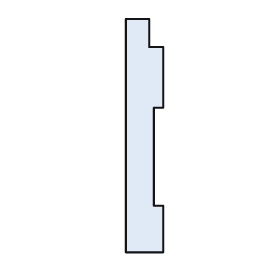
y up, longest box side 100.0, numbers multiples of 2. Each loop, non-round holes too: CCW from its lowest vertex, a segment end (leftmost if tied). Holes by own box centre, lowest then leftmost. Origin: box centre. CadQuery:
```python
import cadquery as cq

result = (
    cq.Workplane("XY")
    .moveTo(-8.0, -50.0)
    .lineTo(8.0, -50.0)
    .lineTo(8.0, -30.0)
    .lineTo(4.0, -30.0)
    .lineTo(4.0, 12.0)
    .lineTo(8.0, 12.0)
    .lineTo(8.0, 38.0)
    .lineTo(2.0, 38.0)
    .lineTo(2.0, 50.0)
    .lineTo(-8.0, 50.0)
    .close()
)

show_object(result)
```